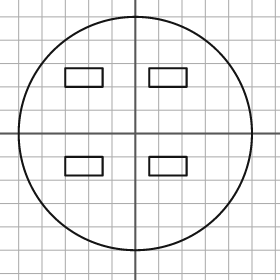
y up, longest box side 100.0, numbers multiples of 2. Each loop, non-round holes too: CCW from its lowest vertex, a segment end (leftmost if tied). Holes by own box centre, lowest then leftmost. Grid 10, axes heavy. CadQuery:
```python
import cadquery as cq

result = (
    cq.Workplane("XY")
    .moveTo(0.0, 0.0)
    .circle(50.0)
    .moveTo(-30.0, -18.0)
    .lineTo(-14.0, -18.0)
    .lineTo(-14.0, -10.0)
    .lineTo(-30.0, -10.0)
    .close()
    .moveTo(6.0, -18.0)
    .lineTo(22.0, -18.0)
    .lineTo(22.0, -10.0)
    .lineTo(6.0, -10.0)
    .close()
    .moveTo(-30.0, 20.0)
    .lineTo(-14.0, 20.0)
    .lineTo(-14.0, 28.0)
    .lineTo(-30.0, 28.0)
    .close()
    .moveTo(6.0, 20.0)
    .lineTo(22.0, 20.0)
    .lineTo(22.0, 28.0)
    .lineTo(6.0, 28.0)
    .close()
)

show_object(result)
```